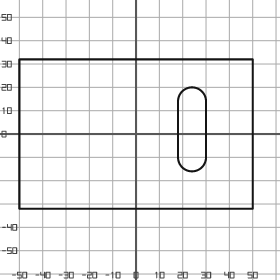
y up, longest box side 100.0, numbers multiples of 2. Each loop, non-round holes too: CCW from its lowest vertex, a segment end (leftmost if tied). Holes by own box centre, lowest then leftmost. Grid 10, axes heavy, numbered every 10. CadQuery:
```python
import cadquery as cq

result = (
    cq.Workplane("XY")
    .moveTo(-50.0, -32.0)
    .lineTo(50.0, -32.0)
    .lineTo(50.0, 32.0)
    .lineTo(-50.0, 32.0)
    .close()
    .moveTo(18.0, -10.0)
    .threePointArc((24.0, -16.0), (30.0, -10.0))
    .lineTo(30.0, 14.0)
    .threePointArc((24.0, 20.0), (18.0, 14.0))
    .close()
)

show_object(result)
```